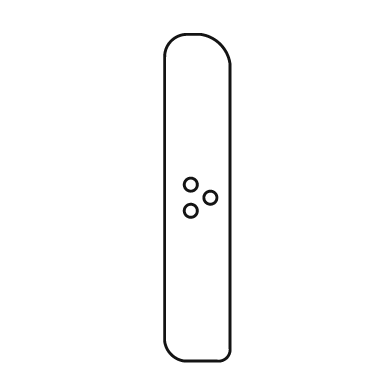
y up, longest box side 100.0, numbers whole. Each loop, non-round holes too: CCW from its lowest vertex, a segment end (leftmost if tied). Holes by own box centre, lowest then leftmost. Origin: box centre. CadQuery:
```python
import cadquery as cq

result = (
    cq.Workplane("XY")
    .moveTo(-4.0, -50.0)
    .lineTo(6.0, -50.0)
    .threePointArc((9.0, -49.0), (10.0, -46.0))
    .lineTo(10.0, 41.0)
    .threePointArc((7.0, 47.0), (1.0, 50.0))
    .lineTo(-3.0, 50.0)
    .threePointArc((-8.0, 48.0), (-10.0, 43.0))
    .lineTo(-10.0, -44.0)
    .threePointArc((-8.0, -48.0), (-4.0, -50.0))
    .close()
    .moveTo(-2.0, -4.0)
    .circle(2.0)
    .moveTo(4.0, 0.0)
    .circle(2.0)
    .moveTo(-2.0, 4.0)
    .circle(2.0)
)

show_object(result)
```